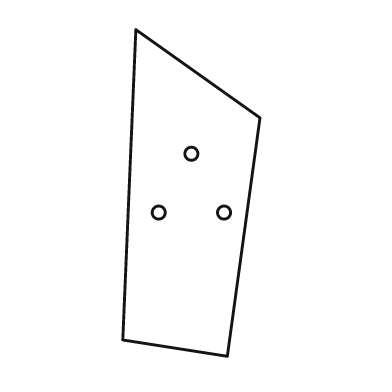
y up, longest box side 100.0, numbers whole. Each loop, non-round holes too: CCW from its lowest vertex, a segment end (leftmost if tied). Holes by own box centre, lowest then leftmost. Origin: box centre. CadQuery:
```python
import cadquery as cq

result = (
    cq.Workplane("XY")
    .moveTo(11.0, -50.0)
    .lineTo(21.0, 23.0)
    .lineTo(-17.0, 50.0)
    .lineTo(-21.0, -45.0)
    .close()
    .moveTo(-10.0, -6.0)
    .circle(2.0)
    .moveTo(10.0, -6.0)
    .circle(2.0)
    .moveTo(0.0, 12.0)
    .circle(2.0)
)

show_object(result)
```